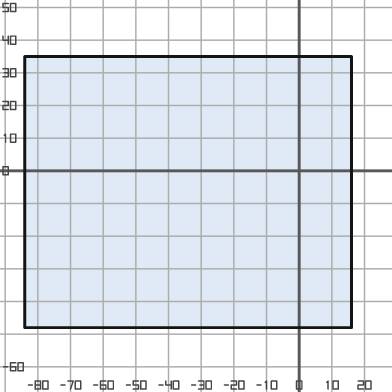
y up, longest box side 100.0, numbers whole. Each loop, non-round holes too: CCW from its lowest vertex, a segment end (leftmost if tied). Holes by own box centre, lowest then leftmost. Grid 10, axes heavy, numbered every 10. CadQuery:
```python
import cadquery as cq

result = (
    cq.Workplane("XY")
    .moveTo(-84.0, -48.0)
    .lineTo(16.0, -48.0)
    .lineTo(16.0, 35.0)
    .lineTo(-84.0, 35.0)
    .close()
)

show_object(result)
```